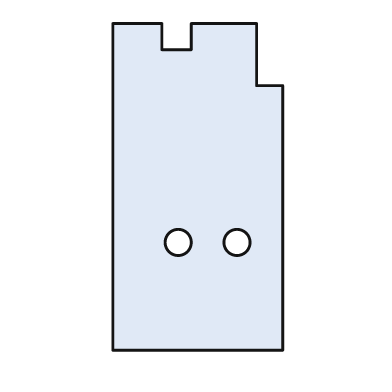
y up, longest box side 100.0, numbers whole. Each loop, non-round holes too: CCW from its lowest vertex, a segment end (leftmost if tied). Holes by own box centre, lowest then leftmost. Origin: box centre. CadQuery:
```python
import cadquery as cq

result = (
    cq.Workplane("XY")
    .moveTo(-26.0, -50.0)
    .lineTo(26.0, -50.0)
    .lineTo(26.0, 31.0)
    .lineTo(18.0, 31.0)
    .lineTo(18.0, 50.0)
    .lineTo(-2.0, 50.0)
    .lineTo(-2.0, 42.0)
    .lineTo(-11.0, 42.0)
    .lineTo(-11.0, 50.0)
    .lineTo(-26.0, 50.0)
    .close()
    .moveTo(-6.0, -17.0)
    .circle(4.0)
    .moveTo(12.0, -17.0)
    .circle(4.0)
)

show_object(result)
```